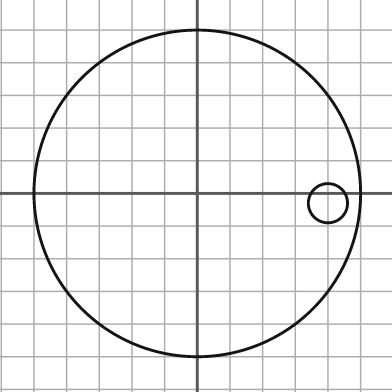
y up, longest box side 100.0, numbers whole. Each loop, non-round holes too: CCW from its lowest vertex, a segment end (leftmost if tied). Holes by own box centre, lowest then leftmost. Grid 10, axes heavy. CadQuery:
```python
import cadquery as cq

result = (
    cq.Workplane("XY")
    .moveTo(0.0, 0.0)
    .circle(50.0)
    .moveTo(40.0, -3.0)
    .circle(6.0)
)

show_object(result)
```